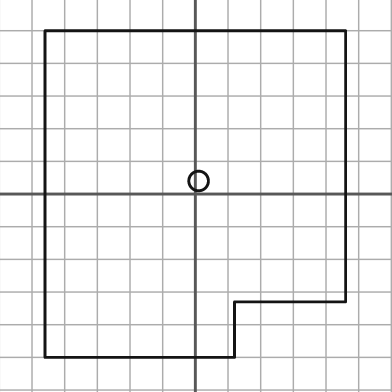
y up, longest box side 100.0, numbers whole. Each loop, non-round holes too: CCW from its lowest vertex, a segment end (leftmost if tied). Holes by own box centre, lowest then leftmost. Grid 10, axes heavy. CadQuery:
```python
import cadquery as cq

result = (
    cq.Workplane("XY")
    .moveTo(-46.0, -50.0)
    .lineTo(12.0, -50.0)
    .lineTo(12.0, -33.0)
    .lineTo(46.0, -33.0)
    .lineTo(46.0, 50.0)
    .lineTo(-46.0, 50.0)
    .close()
    .moveTo(1.0, 4.0)
    .circle(3.0)
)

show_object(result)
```